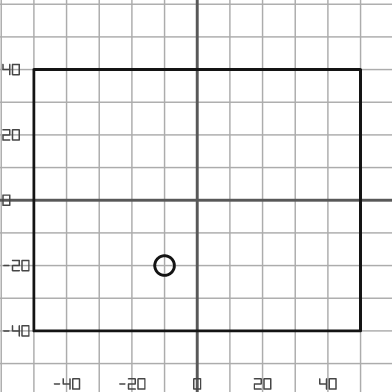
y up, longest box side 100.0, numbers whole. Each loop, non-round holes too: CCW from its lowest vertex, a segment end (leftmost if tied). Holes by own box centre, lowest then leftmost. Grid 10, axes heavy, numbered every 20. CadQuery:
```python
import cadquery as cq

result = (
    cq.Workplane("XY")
    .moveTo(-50.0, -40.0)
    .lineTo(50.0, -40.0)
    .lineTo(50.0, 40.0)
    .lineTo(-50.0, 40.0)
    .close()
    .moveTo(-10.0, -20.0)
    .circle(3.0)
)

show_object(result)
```